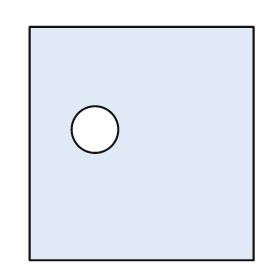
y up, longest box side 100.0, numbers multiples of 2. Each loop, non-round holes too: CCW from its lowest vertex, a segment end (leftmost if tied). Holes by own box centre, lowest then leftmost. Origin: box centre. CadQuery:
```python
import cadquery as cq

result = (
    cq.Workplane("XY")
    .moveTo(-48.0, -50.0)
    .lineTo(48.0, -50.0)
    .lineTo(48.0, 50.0)
    .lineTo(-48.0, 50.0)
    .close()
    .moveTo(-20.0, 6.0)
    .circle(10.0)
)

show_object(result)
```